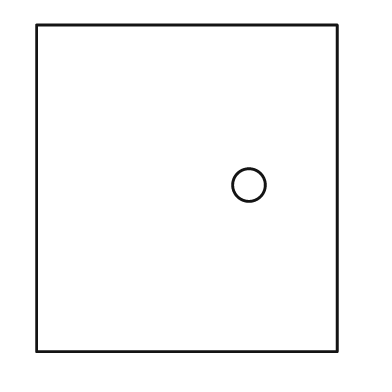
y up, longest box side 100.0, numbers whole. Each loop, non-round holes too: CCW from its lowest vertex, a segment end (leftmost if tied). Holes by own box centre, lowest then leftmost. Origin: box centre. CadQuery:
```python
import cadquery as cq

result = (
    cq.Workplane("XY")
    .moveTo(-46.0, -50.0)
    .lineTo(46.0, -50.0)
    .lineTo(46.0, 50.0)
    .lineTo(-46.0, 50.0)
    .close()
    .moveTo(19.0, 1.0)
    .circle(5.0)
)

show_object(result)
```